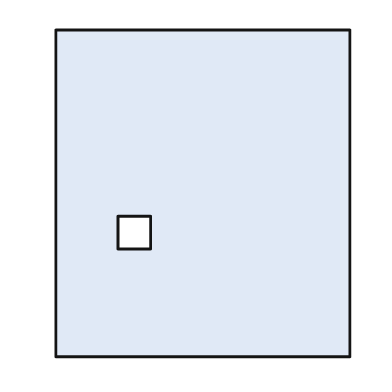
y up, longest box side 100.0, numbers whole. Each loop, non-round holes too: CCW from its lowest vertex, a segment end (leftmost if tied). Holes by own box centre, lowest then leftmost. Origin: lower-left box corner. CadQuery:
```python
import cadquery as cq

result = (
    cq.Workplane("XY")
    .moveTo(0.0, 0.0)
    .lineTo(90.0, 0.0)
    .lineTo(90.0, 100.0)
    .lineTo(0.0, 100.0)
    .close()
    .moveTo(19.0, 33.0)
    .lineTo(29.0, 33.0)
    .lineTo(29.0, 43.0)
    .lineTo(19.0, 43.0)
    .close()
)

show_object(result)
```